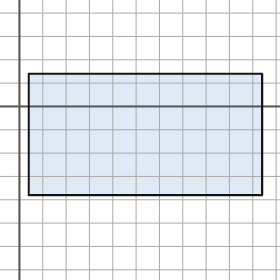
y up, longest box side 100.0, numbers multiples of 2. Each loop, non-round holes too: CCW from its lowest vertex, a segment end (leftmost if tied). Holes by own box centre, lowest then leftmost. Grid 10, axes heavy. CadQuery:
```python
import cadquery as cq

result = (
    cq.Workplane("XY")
    .moveTo(4.0, -38.0)
    .lineTo(104.0, -38.0)
    .lineTo(104.0, 14.0)
    .lineTo(4.0, 14.0)
    .close()
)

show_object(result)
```